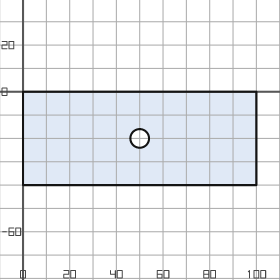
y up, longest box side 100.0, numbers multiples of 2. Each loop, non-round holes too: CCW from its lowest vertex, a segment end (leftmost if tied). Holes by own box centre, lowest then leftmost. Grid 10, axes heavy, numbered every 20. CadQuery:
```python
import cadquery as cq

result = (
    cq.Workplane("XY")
    .moveTo(0.0, -40.0)
    .lineTo(100.0, -40.0)
    .lineTo(100.0, 0.0)
    .lineTo(0.0, 0.0)
    .close()
    .moveTo(50.0, -20.0)
    .circle(4.0)
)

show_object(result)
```